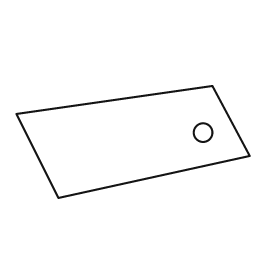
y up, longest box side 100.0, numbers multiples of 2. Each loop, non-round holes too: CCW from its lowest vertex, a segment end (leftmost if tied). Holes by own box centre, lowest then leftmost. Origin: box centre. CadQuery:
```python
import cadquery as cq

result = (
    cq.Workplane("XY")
    .moveTo(-32.0, -24.0)
    .lineTo(50.0, -6.0)
    .lineTo(34.0, 24.0)
    .lineTo(-50.0, 12.0)
    .close()
    .moveTo(30.0, 4.0)
    .circle(4.0)
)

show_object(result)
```